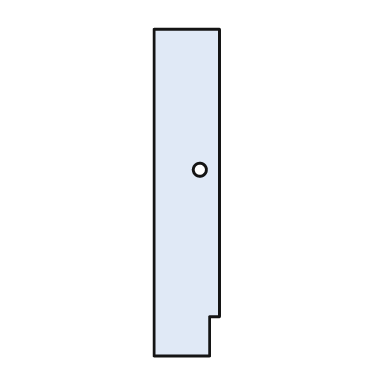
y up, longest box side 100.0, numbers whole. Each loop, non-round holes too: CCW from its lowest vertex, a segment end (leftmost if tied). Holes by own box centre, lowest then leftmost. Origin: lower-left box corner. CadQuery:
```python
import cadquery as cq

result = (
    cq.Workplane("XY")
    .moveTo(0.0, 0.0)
    .lineTo(17.0, 0.0)
    .lineTo(17.0, 12.0)
    .lineTo(20.0, 12.0)
    .lineTo(20.0, 100.0)
    .lineTo(0.0, 100.0)
    .close()
    .moveTo(14.0, 57.0)
    .circle(2.0)
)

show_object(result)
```